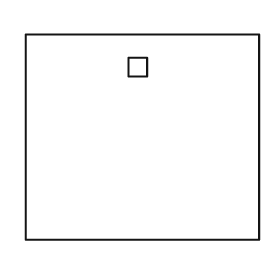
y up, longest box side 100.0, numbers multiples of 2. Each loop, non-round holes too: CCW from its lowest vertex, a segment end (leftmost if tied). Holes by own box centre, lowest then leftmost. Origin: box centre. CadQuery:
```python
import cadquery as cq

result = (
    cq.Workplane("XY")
    .moveTo(-50.0, -44.0)
    .lineTo(50.0, -44.0)
    .lineTo(50.0, 44.0)
    .lineTo(-50.0, 44.0)
    .close()
    .moveTo(-6.0, 26.0)
    .lineTo(2.0, 26.0)
    .lineTo(2.0, 34.0)
    .lineTo(-6.0, 34.0)
    .close()
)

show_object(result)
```